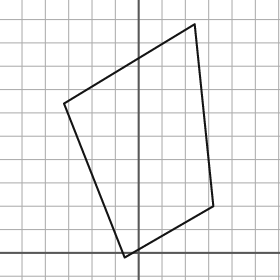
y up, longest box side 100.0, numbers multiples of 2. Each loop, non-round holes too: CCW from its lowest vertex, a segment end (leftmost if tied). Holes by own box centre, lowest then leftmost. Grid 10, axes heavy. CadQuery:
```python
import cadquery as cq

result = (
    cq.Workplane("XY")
    .moveTo(-6.0, -2.0)
    .lineTo(32.0, 20.0)
    .lineTo(24.0, 98.0)
    .lineTo(-32.0, 64.0)
    .close()
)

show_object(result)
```